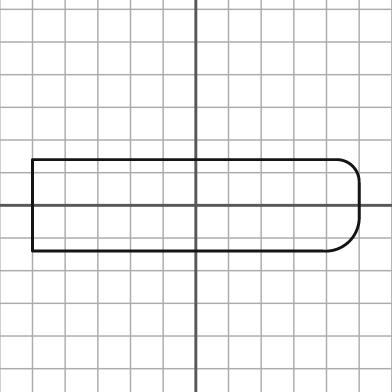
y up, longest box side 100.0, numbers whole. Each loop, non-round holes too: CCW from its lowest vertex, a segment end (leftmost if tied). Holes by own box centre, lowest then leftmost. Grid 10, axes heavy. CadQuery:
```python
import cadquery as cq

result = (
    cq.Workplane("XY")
    .moveTo(-50.0, -14.0)
    .lineTo(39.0, -14.0)
    .threePointArc((47.0, -11.0), (50.0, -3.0))
    .lineTo(50.0, 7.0)
    .threePointArc((48.0, 12.0), (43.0, 14.0))
    .lineTo(-50.0, 14.0)
    .close()
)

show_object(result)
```